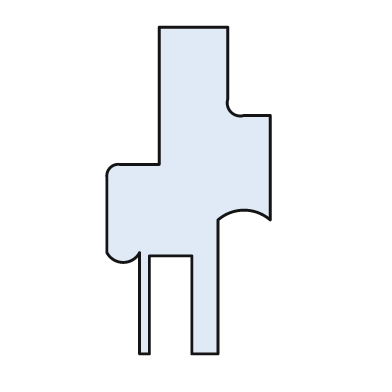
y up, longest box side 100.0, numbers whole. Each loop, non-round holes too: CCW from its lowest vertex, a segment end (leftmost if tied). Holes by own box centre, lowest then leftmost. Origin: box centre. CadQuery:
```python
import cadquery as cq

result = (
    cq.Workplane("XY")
    .moveTo(-15.0, -50.0)
    .lineTo(-12.0, -50.0)
    .lineTo(-12.0, -20.0)
    .lineTo(1.0, -20.0)
    .lineTo(1.0, -50.0)
    .lineTo(9.0, -50.0)
    .lineTo(9.0, -9.0)
    .threePointArc((17.0, -6.0), (25.0, -9.0))
    .lineTo(25.0, 23.0)
    .lineTo(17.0, 23.0)
    .threePointArc((13.0, 24.0), (12.0, 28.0))
    .lineTo(12.0, 50.0)
    .lineTo(-9.0, 50.0)
    .lineTo(-9.0, 8.0)
    .lineTo(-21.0, 8.0)
    .threePointArc((-24.0, 7.0), (-25.0, 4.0))
    .lineTo(-25.0, -19.0)
    .threePointArc((-20.0, -22.0), (-15.0, -19.0))
    .close()
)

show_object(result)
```